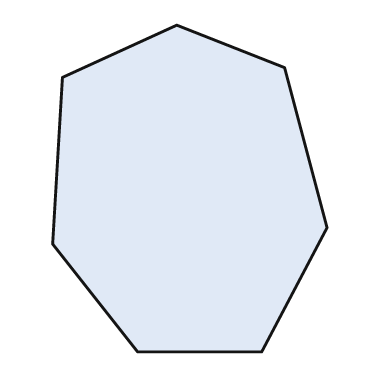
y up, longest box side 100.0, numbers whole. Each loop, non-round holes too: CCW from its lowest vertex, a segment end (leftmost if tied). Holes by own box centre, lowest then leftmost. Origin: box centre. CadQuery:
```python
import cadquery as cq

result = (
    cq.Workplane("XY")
    .moveTo(-16.0, -50.0)
    .lineTo(22.0, -50.0)
    .lineTo(42.0, -12.0)
    .lineTo(29.0, 37.0)
    .lineTo(-4.0, 50.0)
    .lineTo(-39.0, 34.0)
    .lineTo(-42.0, -17.0)
    .close()
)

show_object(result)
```